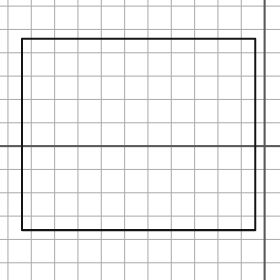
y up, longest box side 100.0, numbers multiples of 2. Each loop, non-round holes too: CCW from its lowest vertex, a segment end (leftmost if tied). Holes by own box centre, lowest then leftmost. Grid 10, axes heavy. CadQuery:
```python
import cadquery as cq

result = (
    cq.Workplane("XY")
    .moveTo(-104.0, -36.0)
    .lineTo(-4.0, -36.0)
    .lineTo(-4.0, 46.0)
    .lineTo(-104.0, 46.0)
    .close()
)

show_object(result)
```